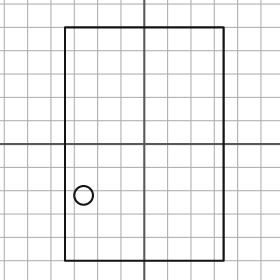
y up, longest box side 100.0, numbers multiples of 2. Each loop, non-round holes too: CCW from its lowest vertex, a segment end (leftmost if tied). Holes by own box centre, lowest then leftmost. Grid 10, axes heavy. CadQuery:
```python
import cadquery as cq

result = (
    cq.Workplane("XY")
    .moveTo(-34.0, -50.0)
    .lineTo(34.0, -50.0)
    .lineTo(34.0, 50.0)
    .lineTo(-34.0, 50.0)
    .close()
    .moveTo(-26.0, -22.0)
    .circle(4.0)
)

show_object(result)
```